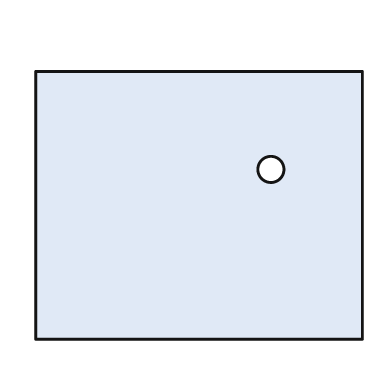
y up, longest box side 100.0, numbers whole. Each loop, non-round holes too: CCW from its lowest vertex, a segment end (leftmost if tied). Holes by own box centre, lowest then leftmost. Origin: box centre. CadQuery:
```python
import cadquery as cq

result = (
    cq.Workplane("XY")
    .moveTo(-50.0, -41.0)
    .lineTo(50.0, -41.0)
    .lineTo(50.0, 41.0)
    .lineTo(-50.0, 41.0)
    .close()
    .moveTo(22.0, 11.0)
    .circle(4.0)
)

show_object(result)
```